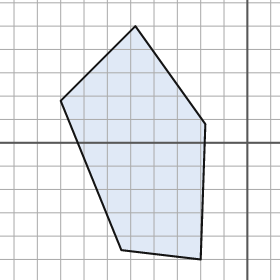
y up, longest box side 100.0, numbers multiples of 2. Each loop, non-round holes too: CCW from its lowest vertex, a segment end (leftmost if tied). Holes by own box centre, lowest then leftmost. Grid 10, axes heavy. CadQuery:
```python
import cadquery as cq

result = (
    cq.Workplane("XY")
    .moveTo(-20.0, -50.0)
    .lineTo(-18.0, 8.0)
    .lineTo(-48.0, 50.0)
    .lineTo(-80.0, 18.0)
    .lineTo(-54.0, -46.0)
    .close()
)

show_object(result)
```